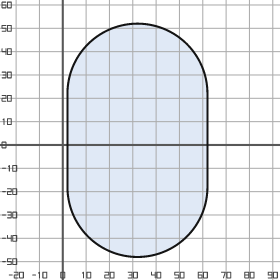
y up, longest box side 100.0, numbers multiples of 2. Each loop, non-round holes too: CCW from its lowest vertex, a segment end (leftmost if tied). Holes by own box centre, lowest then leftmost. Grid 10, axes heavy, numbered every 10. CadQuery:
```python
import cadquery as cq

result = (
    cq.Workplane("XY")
    .moveTo(2.0, -18.0)
    .threePointArc((32.0, -48.0), (62.0, -18.0))
    .lineTo(62.0, 22.0)
    .threePointArc((32.0, 52.0), (2.0, 22.0))
    .close()
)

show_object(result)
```